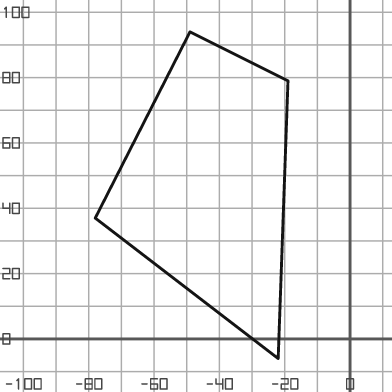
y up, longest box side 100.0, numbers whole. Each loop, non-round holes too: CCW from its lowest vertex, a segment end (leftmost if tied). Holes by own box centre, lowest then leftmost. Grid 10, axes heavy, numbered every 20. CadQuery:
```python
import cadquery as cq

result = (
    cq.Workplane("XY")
    .moveTo(-22.0, -6.0)
    .lineTo(-19.0, 79.0)
    .lineTo(-49.0, 94.0)
    .lineTo(-78.0, 37.0)
    .close()
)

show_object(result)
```